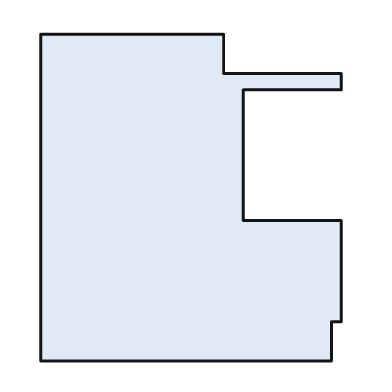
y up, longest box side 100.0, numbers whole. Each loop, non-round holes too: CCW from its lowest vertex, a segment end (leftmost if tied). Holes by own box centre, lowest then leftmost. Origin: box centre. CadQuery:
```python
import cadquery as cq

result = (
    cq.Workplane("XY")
    .moveTo(-46.0, -50.0)
    .lineTo(43.0, -50.0)
    .lineTo(43.0, -38.0)
    .lineTo(46.0, -38.0)
    .lineTo(46.0, -7.0)
    .lineTo(16.0, -7.0)
    .lineTo(16.0, 33.0)
    .lineTo(46.0, 33.0)
    .lineTo(46.0, 38.0)
    .lineTo(10.0, 38.0)
    .lineTo(10.0, 50.0)
    .lineTo(-46.0, 50.0)
    .close()
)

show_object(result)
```